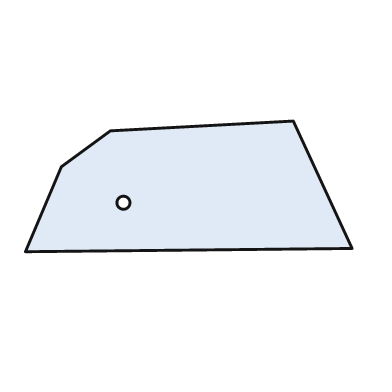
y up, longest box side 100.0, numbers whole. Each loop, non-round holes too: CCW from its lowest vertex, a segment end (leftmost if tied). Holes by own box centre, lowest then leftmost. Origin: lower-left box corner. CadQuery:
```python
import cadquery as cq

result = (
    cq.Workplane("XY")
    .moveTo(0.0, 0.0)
    .lineTo(100.0, 1.0)
    .lineTo(82.0, 40.0)
    .lineTo(26.0, 37.0)
    .lineTo(11.0, 26.0)
    .close()
    .moveTo(30.0, 15.0)
    .circle(2.0)
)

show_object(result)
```